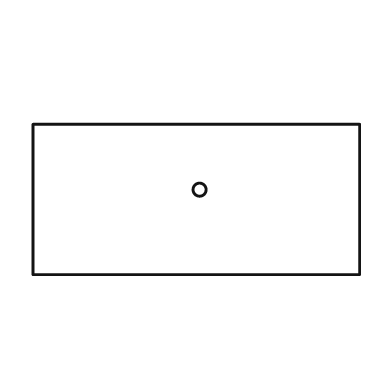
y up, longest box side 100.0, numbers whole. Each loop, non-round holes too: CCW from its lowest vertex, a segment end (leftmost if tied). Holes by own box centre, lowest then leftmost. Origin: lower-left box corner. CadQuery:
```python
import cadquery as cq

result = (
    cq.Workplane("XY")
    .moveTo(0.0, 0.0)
    .lineTo(100.0, 0.0)
    .lineTo(100.0, 46.0)
    .lineTo(0.0, 46.0)
    .close()
    .moveTo(51.0, 26.0)
    .circle(2.0)
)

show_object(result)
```